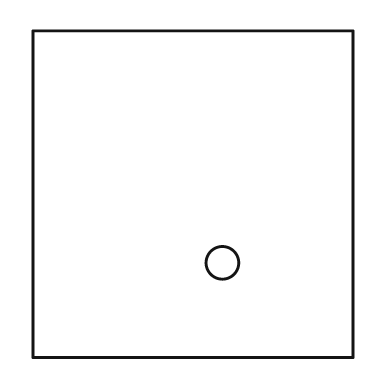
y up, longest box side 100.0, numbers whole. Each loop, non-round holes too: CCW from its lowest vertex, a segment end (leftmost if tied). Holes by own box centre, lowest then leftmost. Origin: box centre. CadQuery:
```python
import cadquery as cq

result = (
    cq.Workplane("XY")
    .moveTo(-49.0, -50.0)
    .lineTo(49.0, -50.0)
    .lineTo(49.0, 50.0)
    .lineTo(-49.0, 50.0)
    .close()
    .moveTo(9.0, -21.0)
    .circle(5.0)
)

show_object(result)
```